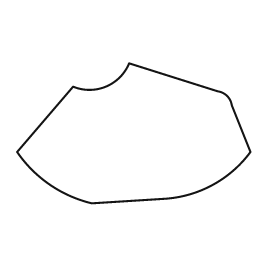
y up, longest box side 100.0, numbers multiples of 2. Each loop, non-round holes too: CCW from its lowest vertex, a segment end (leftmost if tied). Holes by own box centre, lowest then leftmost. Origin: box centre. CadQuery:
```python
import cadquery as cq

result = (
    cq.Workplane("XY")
    .moveTo(-18.0, -30.0)
    .lineTo(14.0, -28.0)
    .threePointArc((34.0, -22.0), (50.0, -8.0))
    .lineTo(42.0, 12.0)
    .threePointArc((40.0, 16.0), (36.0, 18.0))
    .lineTo(-2.0, 30.0)
    .threePointArc((-12.0, 20.0), (-26.0, 20.0))
    .lineTo(-50.0, -8.0)
    .threePointArc((-36.0, -22.0), (-18.0, -30.0))
    .close()
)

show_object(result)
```